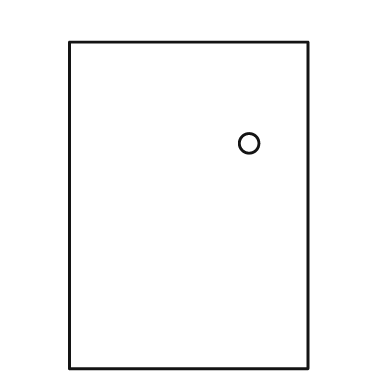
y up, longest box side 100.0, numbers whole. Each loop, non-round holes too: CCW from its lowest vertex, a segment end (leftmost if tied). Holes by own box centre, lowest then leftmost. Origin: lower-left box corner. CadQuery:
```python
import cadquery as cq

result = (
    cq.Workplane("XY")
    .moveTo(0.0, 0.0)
    .lineTo(73.0, 0.0)
    .lineTo(73.0, 100.0)
    .lineTo(0.0, 100.0)
    .close()
    .moveTo(55.0, 69.0)
    .circle(3.0)
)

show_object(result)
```